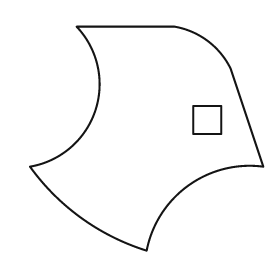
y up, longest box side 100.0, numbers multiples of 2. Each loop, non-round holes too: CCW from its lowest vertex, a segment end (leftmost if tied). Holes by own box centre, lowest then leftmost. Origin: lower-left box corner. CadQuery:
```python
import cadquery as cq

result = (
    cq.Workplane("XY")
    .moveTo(50.0, 0.0)
    .threePointArc((68.0, 28.0), (100.0, 36.0))
    .lineTo(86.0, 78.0)
    .threePointArc((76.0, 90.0), (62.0, 96.0))
    .lineTo(20.0, 96.0)
    .threePointArc((28.0, 60.0), (0.0, 36.0))
    .threePointArc((22.0, 14.0), (50.0, 0.0))
    .close()
    .moveTo(70.0, 50.0)
    .lineTo(82.0, 50.0)
    .lineTo(82.0, 62.0)
    .lineTo(70.0, 62.0)
    .close()
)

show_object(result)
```